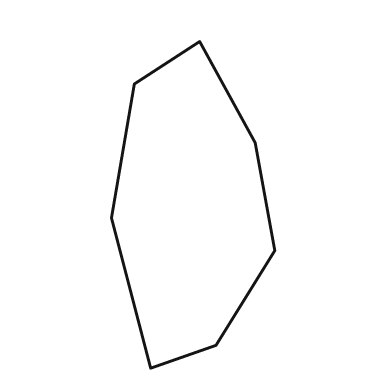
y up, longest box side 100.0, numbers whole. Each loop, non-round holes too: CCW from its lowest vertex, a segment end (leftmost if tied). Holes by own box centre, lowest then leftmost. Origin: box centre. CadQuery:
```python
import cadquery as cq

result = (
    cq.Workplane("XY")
    .moveTo(-13.0, -50.0)
    .lineTo(7.0, -43.0)
    .lineTo(25.0, -14.0)
    .lineTo(19.0, 19.0)
    .lineTo(2.0, 50.0)
    .lineTo(-18.0, 37.0)
    .lineTo(-25.0, -4.0)
    .close()
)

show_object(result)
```